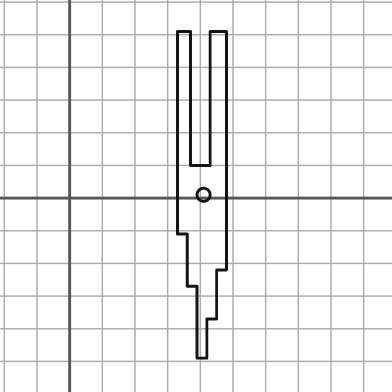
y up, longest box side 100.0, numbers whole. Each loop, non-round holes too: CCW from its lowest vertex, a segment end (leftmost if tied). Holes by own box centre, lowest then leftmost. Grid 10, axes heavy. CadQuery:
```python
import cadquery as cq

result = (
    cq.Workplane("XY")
    .moveTo(39.0, -49.0)
    .lineTo(42.0, -49.0)
    .lineTo(42.0, -37.0)
    .lineTo(45.0, -37.0)
    .lineTo(45.0, -22.0)
    .lineTo(48.0, -22.0)
    .lineTo(48.0, 51.0)
    .lineTo(43.0, 51.0)
    .lineTo(43.0, 10.0)
    .lineTo(37.0, 10.0)
    .lineTo(37.0, 51.0)
    .lineTo(33.0, 51.0)
    .lineTo(33.0, -11.0)
    .lineTo(36.0, -11.0)
    .lineTo(36.0, -27.0)
    .lineTo(39.0, -27.0)
    .close()
    .moveTo(41.0, 1.0)
    .circle(2.0)
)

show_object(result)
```